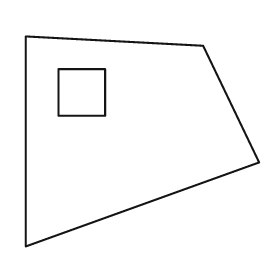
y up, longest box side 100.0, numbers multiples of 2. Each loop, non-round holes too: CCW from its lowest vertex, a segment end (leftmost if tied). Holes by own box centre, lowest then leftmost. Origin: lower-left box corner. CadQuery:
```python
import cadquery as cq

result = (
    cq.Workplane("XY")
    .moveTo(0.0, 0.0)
    .lineTo(100.0, 36.0)
    .lineTo(76.0, 86.0)
    .lineTo(0.0, 90.0)
    .close()
    .moveTo(14.0, 56.0)
    .lineTo(34.0, 56.0)
    .lineTo(34.0, 76.0)
    .lineTo(14.0, 76.0)
    .close()
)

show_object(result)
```